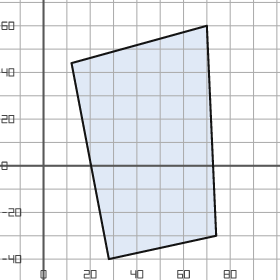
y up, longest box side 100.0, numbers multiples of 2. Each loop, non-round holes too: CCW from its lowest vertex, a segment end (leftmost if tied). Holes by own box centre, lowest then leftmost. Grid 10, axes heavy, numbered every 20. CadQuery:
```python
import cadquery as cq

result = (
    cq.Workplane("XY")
    .moveTo(28.0, -40.0)
    .lineTo(74.0, -30.0)
    .lineTo(70.0, 60.0)
    .lineTo(12.0, 44.0)
    .close()
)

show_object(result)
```